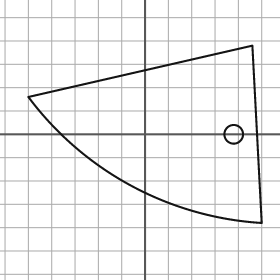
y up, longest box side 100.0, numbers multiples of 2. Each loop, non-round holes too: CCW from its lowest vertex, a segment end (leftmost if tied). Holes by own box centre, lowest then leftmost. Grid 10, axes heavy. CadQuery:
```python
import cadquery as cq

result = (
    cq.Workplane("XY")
    .moveTo(50.0, -38.0)
    .lineTo(46.0, 38.0)
    .lineTo(-50.0, 16.0)
    .threePointArc((-6.0, -22.0), (50.0, -38.0))
    .close()
    .moveTo(38.0, 0.0)
    .circle(4.0)
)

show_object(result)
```